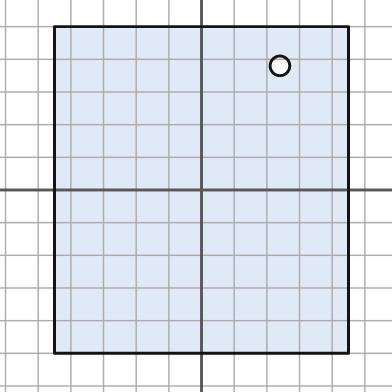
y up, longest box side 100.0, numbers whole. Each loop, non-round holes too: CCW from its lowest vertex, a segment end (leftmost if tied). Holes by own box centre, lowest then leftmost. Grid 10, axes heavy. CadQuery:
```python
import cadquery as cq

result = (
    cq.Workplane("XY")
    .moveTo(-45.0, -50.0)
    .lineTo(45.0, -50.0)
    .lineTo(45.0, 50.0)
    .lineTo(-45.0, 50.0)
    .close()
    .moveTo(24.0, 38.0)
    .circle(3.0)
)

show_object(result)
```